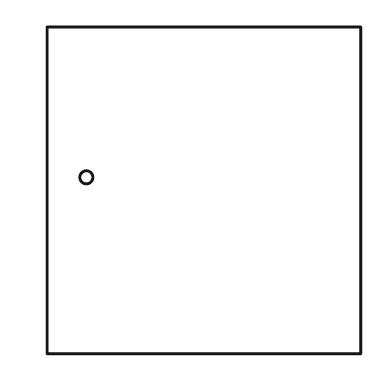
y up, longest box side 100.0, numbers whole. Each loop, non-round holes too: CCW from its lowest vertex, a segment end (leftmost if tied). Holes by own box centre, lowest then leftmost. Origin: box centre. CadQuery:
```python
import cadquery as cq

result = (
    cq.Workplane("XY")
    .moveTo(-48.0, -50.0)
    .lineTo(48.0, -50.0)
    .lineTo(48.0, 50.0)
    .lineTo(-48.0, 50.0)
    .close()
    .moveTo(-36.0, 4.0)
    .circle(2.0)
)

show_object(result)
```